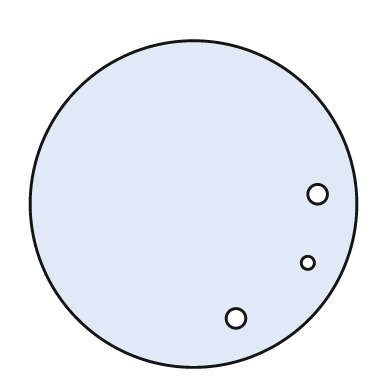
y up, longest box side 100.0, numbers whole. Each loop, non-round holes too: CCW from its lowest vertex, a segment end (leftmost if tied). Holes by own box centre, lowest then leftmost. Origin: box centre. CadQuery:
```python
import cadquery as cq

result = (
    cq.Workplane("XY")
    .moveTo(0.0, 0.0)
    .circle(50.0)
    .moveTo(13.0, -35.0)
    .circle(3.0)
    .moveTo(35.0, -18.0)
    .circle(2.0)
    .moveTo(38.0, 3.0)
    .circle(3.0)
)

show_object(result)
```